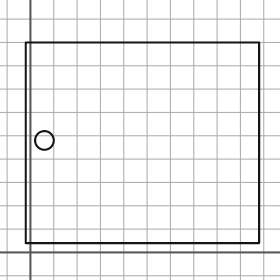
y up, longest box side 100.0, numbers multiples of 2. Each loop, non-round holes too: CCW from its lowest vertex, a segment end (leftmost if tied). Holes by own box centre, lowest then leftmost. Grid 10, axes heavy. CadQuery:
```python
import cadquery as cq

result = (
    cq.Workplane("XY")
    .moveTo(-2.0, 4.0)
    .lineTo(98.0, 4.0)
    .lineTo(98.0, 90.0)
    .lineTo(-2.0, 90.0)
    .close()
    .moveTo(6.0, 48.0)
    .circle(4.0)
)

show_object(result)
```